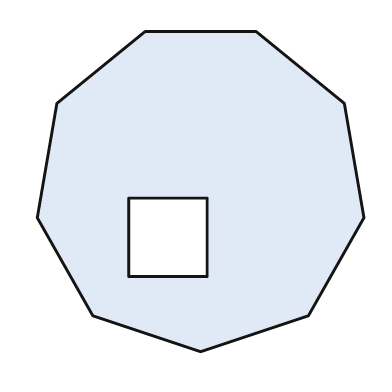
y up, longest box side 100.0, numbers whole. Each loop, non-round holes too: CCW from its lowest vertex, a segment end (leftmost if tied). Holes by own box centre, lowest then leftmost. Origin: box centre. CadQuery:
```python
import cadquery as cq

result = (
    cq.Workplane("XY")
    .moveTo(0.0, -49.0)
    .lineTo(33.0, -38.0)
    .lineTo(50.0, -8.0)
    .lineTo(44.0, 27.0)
    .lineTo(17.0, 49.0)
    .lineTo(-17.0, 49.0)
    .lineTo(-44.0, 27.0)
    .lineTo(-50.0, -8.0)
    .lineTo(-33.0, -38.0)
    .close()
    .moveTo(-22.0, -26.0)
    .lineTo(2.0, -26.0)
    .lineTo(2.0, -2.0)
    .lineTo(-22.0, -2.0)
    .close()
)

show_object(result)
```